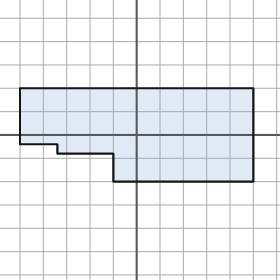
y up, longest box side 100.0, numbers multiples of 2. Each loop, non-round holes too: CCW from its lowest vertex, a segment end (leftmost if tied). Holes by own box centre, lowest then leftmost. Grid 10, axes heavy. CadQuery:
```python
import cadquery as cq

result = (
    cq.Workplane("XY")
    .moveTo(-10.0, -20.0)
    .lineTo(50.0, -20.0)
    .lineTo(50.0, 20.0)
    .lineTo(-50.0, 20.0)
    .lineTo(-50.0, -4.0)
    .lineTo(-34.0, -4.0)
    .lineTo(-34.0, -8.0)
    .lineTo(-10.0, -8.0)
    .close()
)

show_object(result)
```